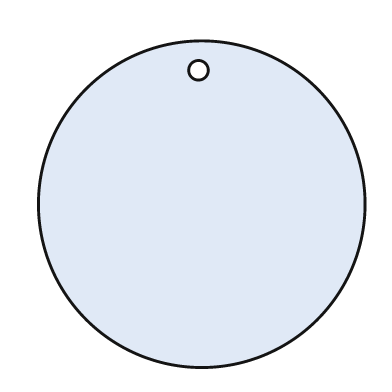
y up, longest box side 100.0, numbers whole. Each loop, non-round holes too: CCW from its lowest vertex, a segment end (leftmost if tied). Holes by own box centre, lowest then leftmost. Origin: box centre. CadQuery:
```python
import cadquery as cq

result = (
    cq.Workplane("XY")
    .moveTo(0.0, 0.0)
    .circle(50.0)
    .moveTo(-1.0, 41.0)
    .circle(3.0)
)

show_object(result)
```